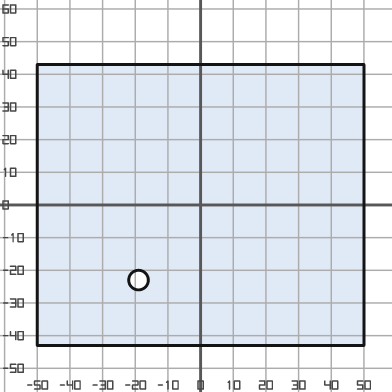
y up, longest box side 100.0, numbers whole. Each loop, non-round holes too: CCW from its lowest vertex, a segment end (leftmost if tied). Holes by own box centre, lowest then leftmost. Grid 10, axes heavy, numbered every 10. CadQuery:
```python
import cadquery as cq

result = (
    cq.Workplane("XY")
    .moveTo(-50.0, -43.0)
    .lineTo(50.0, -43.0)
    .lineTo(50.0, 43.0)
    .lineTo(-50.0, 43.0)
    .close()
    .moveTo(-19.0, -23.0)
    .circle(3.0)
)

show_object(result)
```